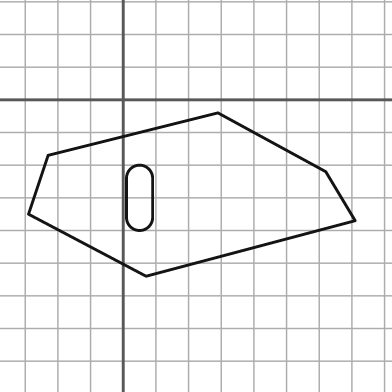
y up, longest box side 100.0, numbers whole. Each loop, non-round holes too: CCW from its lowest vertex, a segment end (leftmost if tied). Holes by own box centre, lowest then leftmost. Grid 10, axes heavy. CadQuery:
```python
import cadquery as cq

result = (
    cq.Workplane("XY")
    .moveTo(7.0, -54.0)
    .lineTo(71.0, -37.0)
    .lineTo(62.0, -22.0)
    .lineTo(29.0, -4.0)
    .lineTo(-23.0, -17.0)
    .lineTo(-29.0, -35.0)
    .close()
    .moveTo(1.0, -36.0)
    .threePointArc((5.0, -40.0), (9.0, -36.0))
    .lineTo(9.0, -24.0)
    .threePointArc((5.0, -20.0), (1.0, -24.0))
    .close()
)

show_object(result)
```